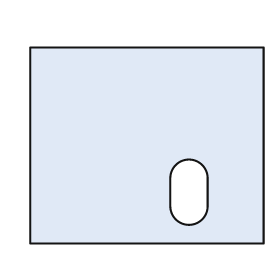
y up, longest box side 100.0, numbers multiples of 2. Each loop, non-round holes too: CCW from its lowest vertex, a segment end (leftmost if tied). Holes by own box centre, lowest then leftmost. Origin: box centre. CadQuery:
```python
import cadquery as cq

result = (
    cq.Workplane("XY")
    .moveTo(-50.0, -42.0)
    .lineTo(50.0, -42.0)
    .lineTo(50.0, 42.0)
    .lineTo(-50.0, 42.0)
    .close()
    .moveTo(10.0, -26.0)
    .threePointArc((18.0, -34.0), (26.0, -26.0))
    .lineTo(26.0, -14.0)
    .threePointArc((18.0, -6.0), (10.0, -14.0))
    .close()
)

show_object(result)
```